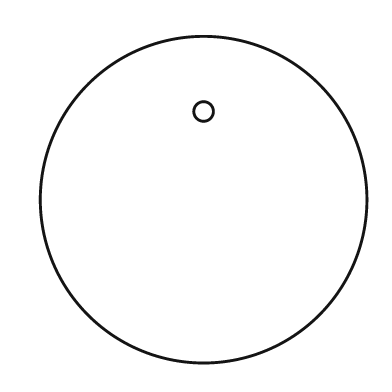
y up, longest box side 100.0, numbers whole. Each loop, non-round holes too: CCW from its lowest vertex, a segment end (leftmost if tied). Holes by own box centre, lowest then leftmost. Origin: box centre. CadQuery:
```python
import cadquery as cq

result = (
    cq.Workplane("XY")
    .moveTo(0.0, 0.0)
    .circle(50.0)
    .moveTo(0.0, 27.0)
    .circle(3.0)
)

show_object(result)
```